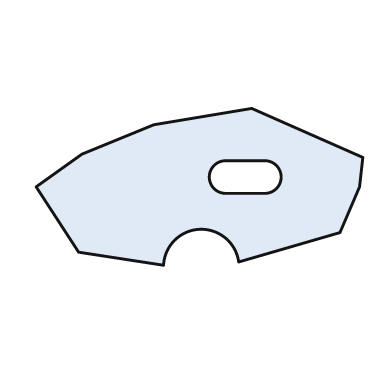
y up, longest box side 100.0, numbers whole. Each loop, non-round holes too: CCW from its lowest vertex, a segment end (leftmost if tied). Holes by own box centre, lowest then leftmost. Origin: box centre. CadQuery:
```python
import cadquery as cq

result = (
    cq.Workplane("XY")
    .moveTo(-11.0, -24.0)
    .threePointArc((0.0, -13.0), (12.0, -23.0))
    .lineTo(43.0, -14.0)
    .lineTo(49.0, 0.0)
    .lineTo(50.0, 9.0)
    .lineTo(16.0, 24.0)
    .lineTo(-14.0, 19.0)
    .lineTo(-36.0, 10.0)
    .lineTo(-50.0, 0.0)
    .lineTo(-37.0, -20.0)
    .close()
    .moveTo(8.0, -2.0)
    .lineTo(20.0, -2.0)
    .threePointArc((25.0, 3.0), (20.0, 8.0))
    .lineTo(8.0, 8.0)
    .threePointArc((3.0, 3.0), (8.0, -2.0))
    .close()
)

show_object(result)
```